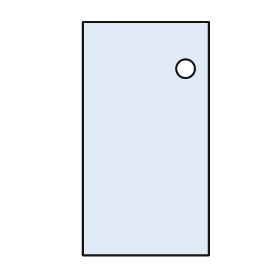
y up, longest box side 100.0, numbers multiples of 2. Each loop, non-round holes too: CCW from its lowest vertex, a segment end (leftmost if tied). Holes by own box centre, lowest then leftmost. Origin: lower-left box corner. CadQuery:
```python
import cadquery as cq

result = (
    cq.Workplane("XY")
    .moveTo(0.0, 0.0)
    .lineTo(54.0, 0.0)
    .lineTo(54.0, 100.0)
    .lineTo(0.0, 100.0)
    .close()
    .moveTo(44.0, 80.0)
    .circle(4.0)
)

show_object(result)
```